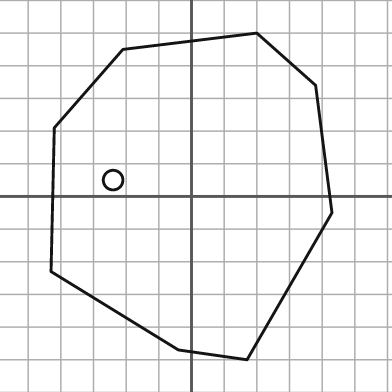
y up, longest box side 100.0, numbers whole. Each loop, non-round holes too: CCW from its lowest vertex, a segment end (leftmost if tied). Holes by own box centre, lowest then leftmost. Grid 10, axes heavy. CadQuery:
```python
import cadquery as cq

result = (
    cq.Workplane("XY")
    .moveTo(17.0, -50.0)
    .lineTo(43.0, -5.0)
    .lineTo(38.0, 34.0)
    .lineTo(20.0, 50.0)
    .lineTo(-21.0, 45.0)
    .lineTo(-42.0, 21.0)
    .lineTo(-43.0, -23.0)
    .lineTo(-4.0, -47.0)
    .close()
    .moveTo(-24.0, 5.0)
    .circle(3.0)
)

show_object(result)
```